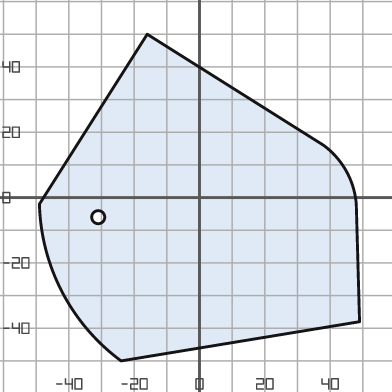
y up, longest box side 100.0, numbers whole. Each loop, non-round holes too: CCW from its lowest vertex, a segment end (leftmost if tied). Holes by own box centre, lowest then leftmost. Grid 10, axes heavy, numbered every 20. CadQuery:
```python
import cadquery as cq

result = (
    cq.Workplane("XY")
    .moveTo(-24.0, -50.0)
    .lineTo(49.0, -38.0)
    .lineTo(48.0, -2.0)
    .threePointArc((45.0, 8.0), (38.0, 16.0))
    .lineTo(-16.0, 50.0)
    .lineTo(-49.0, -2.0)
    .threePointArc((-42.0, -29.0), (-24.0, -50.0))
    .close()
    .moveTo(-31.0, -6.0)
    .circle(2.0)
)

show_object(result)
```